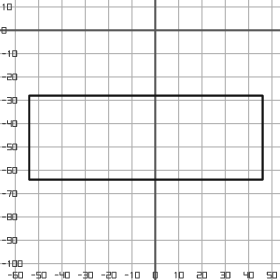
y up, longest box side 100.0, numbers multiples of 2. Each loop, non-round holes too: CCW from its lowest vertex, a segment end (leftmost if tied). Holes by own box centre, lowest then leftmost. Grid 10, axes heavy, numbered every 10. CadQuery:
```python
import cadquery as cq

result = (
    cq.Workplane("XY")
    .moveTo(-54.0, -64.0)
    .lineTo(46.0, -64.0)
    .lineTo(46.0, -28.0)
    .lineTo(-54.0, -28.0)
    .close()
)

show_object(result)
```